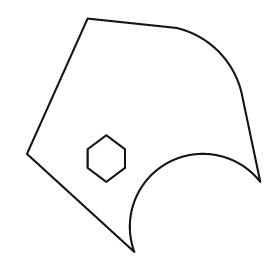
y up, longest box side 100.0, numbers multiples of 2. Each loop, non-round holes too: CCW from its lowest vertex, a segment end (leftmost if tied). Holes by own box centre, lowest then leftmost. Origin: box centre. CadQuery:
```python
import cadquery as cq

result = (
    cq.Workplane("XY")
    .moveTo(-4.0, -50.0)
    .threePointArc((10.0, -12.0), (50.0, -20.0))
    .lineTo(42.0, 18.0)
    .threePointArc((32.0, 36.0), (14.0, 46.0))
    .lineTo(-24.0, 50.0)
    .lineTo(-50.0, -8.0)
    .close()
    .moveTo(-16.0, -20.0)
    .lineTo(-8.0, -14.0)
    .lineTo(-8.0, -6.0)
    .lineTo(-16.0, 0.0)
    .lineTo(-24.0, -6.0)
    .lineTo(-24.0, -14.0)
    .close()
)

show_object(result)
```